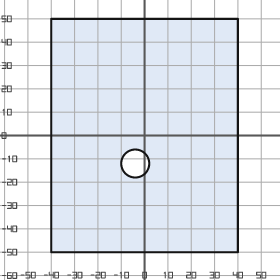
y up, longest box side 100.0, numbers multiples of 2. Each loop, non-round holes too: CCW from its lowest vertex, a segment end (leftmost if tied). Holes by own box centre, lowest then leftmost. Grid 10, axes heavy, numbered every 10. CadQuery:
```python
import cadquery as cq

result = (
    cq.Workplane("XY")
    .moveTo(-40.0, -50.0)
    .lineTo(40.0, -50.0)
    .lineTo(40.0, 50.0)
    .lineTo(-40.0, 50.0)
    .close()
    .moveTo(-4.0, -12.0)
    .circle(6.0)
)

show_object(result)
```